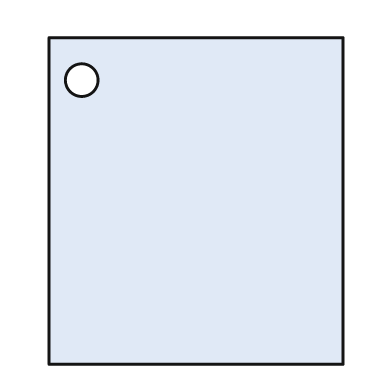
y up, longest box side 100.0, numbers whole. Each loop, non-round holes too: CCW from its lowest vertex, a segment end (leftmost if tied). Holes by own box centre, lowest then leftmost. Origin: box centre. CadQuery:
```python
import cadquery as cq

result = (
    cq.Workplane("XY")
    .moveTo(-45.0, -50.0)
    .lineTo(45.0, -50.0)
    .lineTo(45.0, 50.0)
    .lineTo(-45.0, 50.0)
    .close()
    .moveTo(-35.0, 37.0)
    .circle(5.0)
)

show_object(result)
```